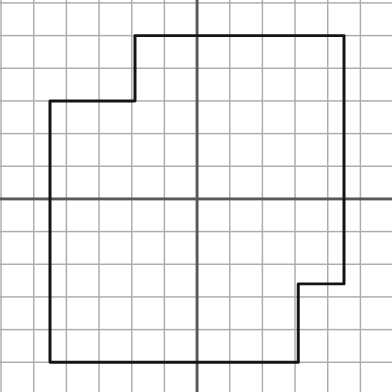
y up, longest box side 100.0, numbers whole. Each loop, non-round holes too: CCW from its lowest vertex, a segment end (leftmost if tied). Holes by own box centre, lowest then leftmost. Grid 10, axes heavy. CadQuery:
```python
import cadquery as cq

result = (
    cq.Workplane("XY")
    .moveTo(-45.0, -50.0)
    .lineTo(31.0, -50.0)
    .lineTo(31.0, -26.0)
    .lineTo(45.0, -26.0)
    .lineTo(45.0, 50.0)
    .lineTo(-19.0, 50.0)
    .lineTo(-19.0, 30.0)
    .lineTo(-45.0, 30.0)
    .close()
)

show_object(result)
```